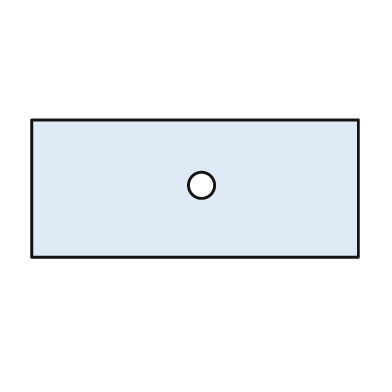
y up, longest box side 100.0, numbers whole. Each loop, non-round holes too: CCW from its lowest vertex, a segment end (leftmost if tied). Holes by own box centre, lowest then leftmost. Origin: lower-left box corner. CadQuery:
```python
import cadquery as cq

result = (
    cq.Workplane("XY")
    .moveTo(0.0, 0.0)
    .lineTo(100.0, 0.0)
    .lineTo(100.0, 42.0)
    .lineTo(0.0, 42.0)
    .close()
    .moveTo(52.0, 22.0)
    .circle(4.0)
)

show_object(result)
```